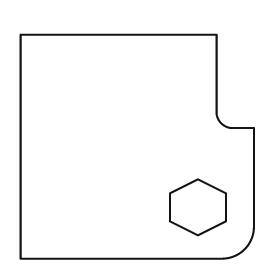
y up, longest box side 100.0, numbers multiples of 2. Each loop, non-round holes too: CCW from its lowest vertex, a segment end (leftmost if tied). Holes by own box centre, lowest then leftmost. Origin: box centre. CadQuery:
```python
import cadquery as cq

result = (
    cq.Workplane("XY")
    .moveTo(-50.0, -48.0)
    .lineTo(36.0, -48.0)
    .threePointArc((46.0, -44.0), (50.0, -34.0))
    .lineTo(50.0, 8.0)
    .lineTo(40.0, 8.0)
    .threePointArc((36.0, 10.0), (34.0, 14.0))
    .lineTo(34.0, 48.0)
    .lineTo(-50.0, 48.0)
    .close()
    .moveTo(26.0, -38.0)
    .lineTo(38.0, -32.0)
    .lineTo(38.0, -20.0)
    .lineTo(26.0, -14.0)
    .lineTo(14.0, -20.0)
    .lineTo(14.0, -32.0)
    .close()
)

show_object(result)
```